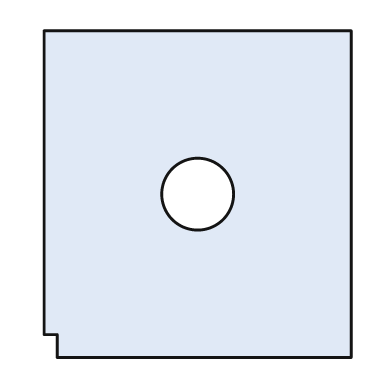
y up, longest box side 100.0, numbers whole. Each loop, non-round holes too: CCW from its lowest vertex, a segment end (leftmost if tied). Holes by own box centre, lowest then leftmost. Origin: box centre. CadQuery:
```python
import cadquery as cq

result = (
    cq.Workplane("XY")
    .moveTo(-43.0, -50.0)
    .lineTo(47.0, -50.0)
    .lineTo(47.0, 50.0)
    .lineTo(-47.0, 50.0)
    .lineTo(-47.0, -43.0)
    .lineTo(-43.0, -43.0)
    .close()
    .moveTo(0.0, 0.0)
    .circle(11.0)
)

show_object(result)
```